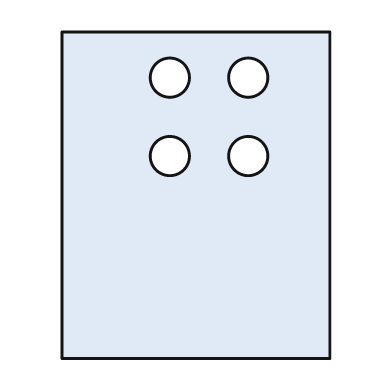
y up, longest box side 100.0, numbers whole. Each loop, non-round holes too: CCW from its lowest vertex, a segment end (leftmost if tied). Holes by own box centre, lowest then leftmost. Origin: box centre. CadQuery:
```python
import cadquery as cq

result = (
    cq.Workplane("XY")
    .moveTo(-41.0, -50.0)
    .lineTo(41.0, -50.0)
    .lineTo(41.0, 50.0)
    .lineTo(-41.0, 50.0)
    .close()
    .moveTo(-8.0, 12.0)
    .circle(6.0)
    .moveTo(16.0, 12.0)
    .circle(6.0)
    .moveTo(-8.0, 36.0)
    .circle(6.0)
    .moveTo(16.0, 36.0)
    .circle(6.0)
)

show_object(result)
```